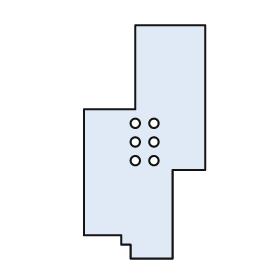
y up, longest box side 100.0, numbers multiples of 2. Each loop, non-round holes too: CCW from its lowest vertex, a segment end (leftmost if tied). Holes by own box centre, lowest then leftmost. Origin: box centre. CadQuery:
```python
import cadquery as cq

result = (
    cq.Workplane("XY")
    .moveTo(-6.0, -50.0)
    .lineTo(12.0, -50.0)
    .lineTo(12.0, -12.0)
    .lineTo(26.0, -12.0)
    .lineTo(26.0, 50.0)
    .lineTo(-4.0, 50.0)
    .lineTo(-4.0, 14.0)
    .lineTo(-26.0, 14.0)
    .lineTo(-26.0, -40.0)
    .lineTo(-10.0, -40.0)
    .lineTo(-10.0, -44.0)
    .lineTo(-6.0, -44.0)
    .close()
    .moveTo(-4.0, -8.0)
    .circle(2.0)
    .moveTo(4.0, -8.0)
    .circle(2.0)
    .moveTo(-4.0, 0.0)
    .circle(2.0)
    .moveTo(4.0, 0.0)
    .circle(2.0)
    .moveTo(-4.0, 8.0)
    .circle(2.0)
    .moveTo(4.0, 8.0)
    .circle(2.0)
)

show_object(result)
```